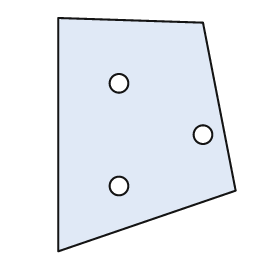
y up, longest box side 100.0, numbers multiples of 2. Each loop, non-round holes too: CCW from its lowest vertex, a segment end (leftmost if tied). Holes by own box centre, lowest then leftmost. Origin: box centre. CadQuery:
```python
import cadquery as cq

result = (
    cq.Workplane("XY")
    .moveTo(-38.0, -50.0)
    .lineTo(38.0, -24.0)
    .lineTo(24.0, 48.0)
    .lineTo(-38.0, 50.0)
    .close()
    .moveTo(-12.0, -22.0)
    .circle(4.0)
    .moveTo(24.0, 0.0)
    .circle(4.0)
    .moveTo(-12.0, 22.0)
    .circle(4.0)
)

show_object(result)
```